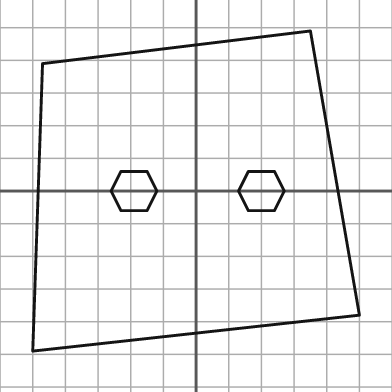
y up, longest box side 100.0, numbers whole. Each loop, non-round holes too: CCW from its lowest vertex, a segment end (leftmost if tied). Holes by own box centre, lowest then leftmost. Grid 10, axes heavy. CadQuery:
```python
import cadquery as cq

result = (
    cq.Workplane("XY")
    .moveTo(-50.0, -49.0)
    .lineTo(50.0, -38.0)
    .lineTo(35.0, 49.0)
    .lineTo(-47.0, 39.0)
    .close()
    .moveTo(-23.0, -6.0)
    .lineTo(-15.0, -6.0)
    .lineTo(-12.0, 0.0)
    .lineTo(-15.0, 6.0)
    .lineTo(-23.0, 6.0)
    .lineTo(-26.0, 0.0)
    .close()
    .moveTo(16.0, -6.0)
    .lineTo(24.0, -6.0)
    .lineTo(27.0, 0.0)
    .lineTo(24.0, 6.0)
    .lineTo(16.0, 6.0)
    .lineTo(13.0, 0.0)
    .close()
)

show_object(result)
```